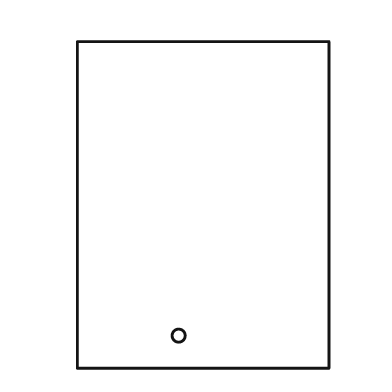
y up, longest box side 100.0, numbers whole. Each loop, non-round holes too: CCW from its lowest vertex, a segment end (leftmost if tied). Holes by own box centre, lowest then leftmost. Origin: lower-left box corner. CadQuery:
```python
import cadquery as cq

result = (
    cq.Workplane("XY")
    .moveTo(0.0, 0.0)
    .lineTo(77.0, 0.0)
    .lineTo(77.0, 100.0)
    .lineTo(0.0, 100.0)
    .close()
    .moveTo(31.0, 10.0)
    .circle(2.0)
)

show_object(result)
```